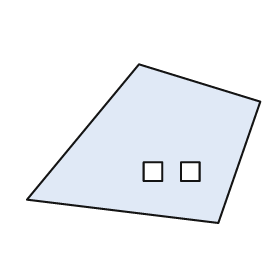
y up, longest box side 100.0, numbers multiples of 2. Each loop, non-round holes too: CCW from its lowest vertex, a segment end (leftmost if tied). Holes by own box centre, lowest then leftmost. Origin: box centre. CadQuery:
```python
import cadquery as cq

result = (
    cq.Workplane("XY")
    .moveTo(32.0, -34.0)
    .lineTo(50.0, 18.0)
    .lineTo(-2.0, 34.0)
    .lineTo(-50.0, -24.0)
    .close()
    .moveTo(0.0, -16.0)
    .lineTo(8.0, -16.0)
    .lineTo(8.0, -8.0)
    .lineTo(0.0, -8.0)
    .close()
    .moveTo(16.0, -16.0)
    .lineTo(24.0, -16.0)
    .lineTo(24.0, -8.0)
    .lineTo(16.0, -8.0)
    .close()
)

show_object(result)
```